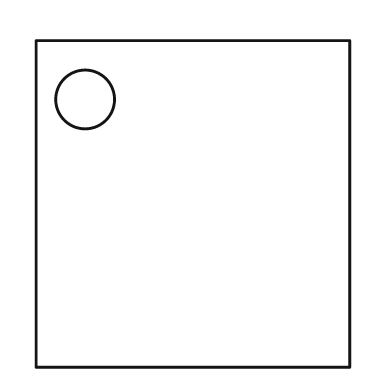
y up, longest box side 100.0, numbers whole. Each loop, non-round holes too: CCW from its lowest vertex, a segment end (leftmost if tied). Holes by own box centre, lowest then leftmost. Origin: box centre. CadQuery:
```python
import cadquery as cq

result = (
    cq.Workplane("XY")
    .moveTo(-48.0, -50.0)
    .lineTo(48.0, -50.0)
    .lineTo(48.0, 50.0)
    .lineTo(-48.0, 50.0)
    .close()
    .moveTo(-33.0, 32.0)
    .circle(9.0)
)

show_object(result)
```